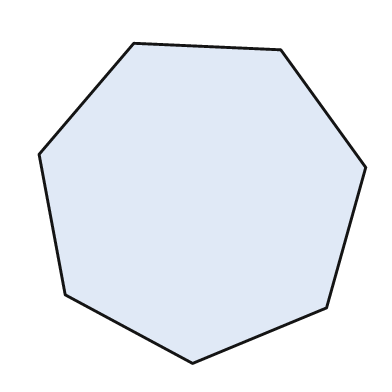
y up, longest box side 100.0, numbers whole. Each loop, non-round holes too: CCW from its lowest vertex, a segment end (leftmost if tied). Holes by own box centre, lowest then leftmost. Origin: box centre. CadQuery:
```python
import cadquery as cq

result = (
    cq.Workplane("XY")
    .moveTo(-3.0, -49.0)
    .lineTo(38.0, -32.0)
    .lineTo(50.0, 11.0)
    .lineTo(24.0, 47.0)
    .lineTo(-21.0, 49.0)
    .lineTo(-50.0, 15.0)
    .lineTo(-42.0, -28.0)
    .close()
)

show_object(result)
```